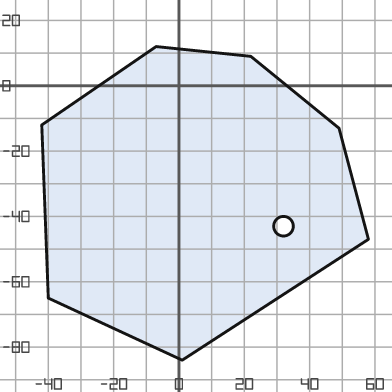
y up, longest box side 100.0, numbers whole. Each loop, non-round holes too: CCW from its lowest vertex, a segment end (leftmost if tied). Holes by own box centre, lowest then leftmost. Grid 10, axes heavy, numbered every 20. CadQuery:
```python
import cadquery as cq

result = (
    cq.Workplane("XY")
    .moveTo(1.0, -84.0)
    .lineTo(58.0, -47.0)
    .lineTo(49.0, -13.0)
    .lineTo(22.0, 9.0)
    .lineTo(-7.0, 12.0)
    .lineTo(-42.0, -12.0)
    .lineTo(-40.0, -65.0)
    .close()
    .moveTo(32.0, -43.0)
    .circle(3.0)
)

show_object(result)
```